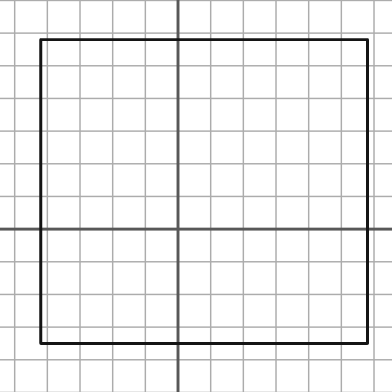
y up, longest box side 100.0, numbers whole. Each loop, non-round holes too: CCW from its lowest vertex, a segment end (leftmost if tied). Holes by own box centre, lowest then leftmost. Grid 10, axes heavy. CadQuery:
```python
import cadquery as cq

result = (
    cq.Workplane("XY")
    .moveTo(-42.0, -35.0)
    .lineTo(58.0, -35.0)
    .lineTo(58.0, 58.0)
    .lineTo(-42.0, 58.0)
    .close()
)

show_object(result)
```